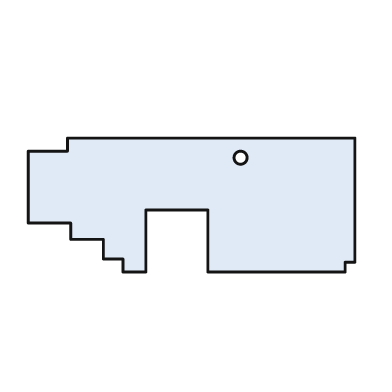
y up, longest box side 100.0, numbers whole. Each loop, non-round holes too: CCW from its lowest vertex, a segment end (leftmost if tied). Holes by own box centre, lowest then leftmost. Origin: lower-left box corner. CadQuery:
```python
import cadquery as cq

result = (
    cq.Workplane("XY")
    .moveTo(29.0, 0.0)
    .lineTo(36.0, 0.0)
    .lineTo(36.0, 19.0)
    .lineTo(55.0, 19.0)
    .lineTo(55.0, 0.0)
    .lineTo(97.0, 0.0)
    .lineTo(97.0, 3.0)
    .lineTo(100.0, 3.0)
    .lineTo(100.0, 41.0)
    .lineTo(12.0, 41.0)
    .lineTo(12.0, 37.0)
    .lineTo(0.0, 37.0)
    .lineTo(0.0, 15.0)
    .lineTo(13.0, 15.0)
    .lineTo(13.0, 10.0)
    .lineTo(23.0, 10.0)
    .lineTo(23.0, 4.0)
    .lineTo(29.0, 4.0)
    .close()
    .moveTo(65.0, 35.0)
    .circle(2.0)
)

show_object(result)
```